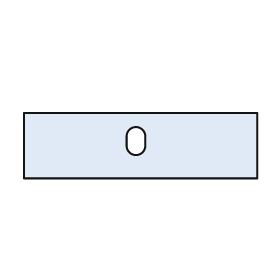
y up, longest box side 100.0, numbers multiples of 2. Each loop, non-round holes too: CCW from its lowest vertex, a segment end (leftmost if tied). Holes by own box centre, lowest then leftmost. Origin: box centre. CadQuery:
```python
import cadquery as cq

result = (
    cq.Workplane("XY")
    .moveTo(-50.0, -14.0)
    .lineTo(50.0, -14.0)
    .lineTo(50.0, 14.0)
    .lineTo(-50.0, 14.0)
    .close()
    .moveTo(-6.0, 0.0)
    .threePointArc((-2.0, -4.0), (2.0, 0.0))
    .lineTo(2.0, 4.0)
    .threePointArc((-2.0, 8.0), (-6.0, 4.0))
    .close()
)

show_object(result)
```